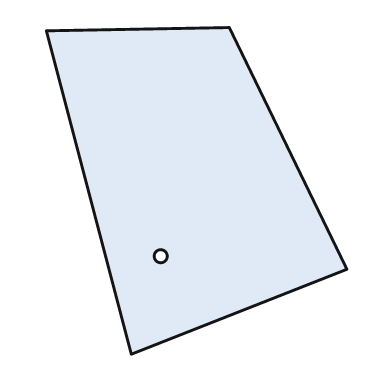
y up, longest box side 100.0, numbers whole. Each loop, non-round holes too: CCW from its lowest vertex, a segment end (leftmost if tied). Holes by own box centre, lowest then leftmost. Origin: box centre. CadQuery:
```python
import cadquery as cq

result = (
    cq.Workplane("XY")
    .moveTo(-20.0, -50.0)
    .lineTo(46.0, -24.0)
    .lineTo(10.0, 50.0)
    .lineTo(-46.0, 49.0)
    .close()
    .moveTo(-11.0, -20.0)
    .circle(2.0)
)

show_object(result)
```